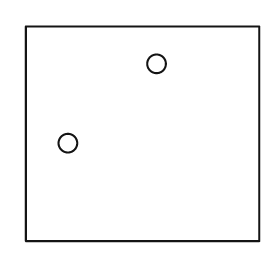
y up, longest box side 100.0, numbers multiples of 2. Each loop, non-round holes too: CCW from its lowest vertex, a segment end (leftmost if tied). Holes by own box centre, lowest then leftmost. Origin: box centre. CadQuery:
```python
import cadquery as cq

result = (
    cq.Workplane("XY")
    .moveTo(-50.0, -46.0)
    .lineTo(50.0, -46.0)
    .lineTo(50.0, 46.0)
    .lineTo(-50.0, 46.0)
    .close()
    .moveTo(-32.0, -4.0)
    .circle(4.0)
    .moveTo(6.0, 30.0)
    .circle(4.0)
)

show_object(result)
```